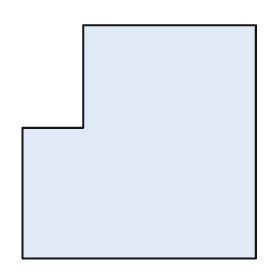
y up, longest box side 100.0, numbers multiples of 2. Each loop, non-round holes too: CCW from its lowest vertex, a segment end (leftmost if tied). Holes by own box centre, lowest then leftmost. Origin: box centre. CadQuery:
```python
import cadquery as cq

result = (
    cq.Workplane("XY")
    .moveTo(-50.0, -50.0)
    .lineTo(50.0, -50.0)
    .lineTo(50.0, 50.0)
    .lineTo(-24.0, 50.0)
    .lineTo(-24.0, 6.0)
    .lineTo(-50.0, 6.0)
    .close()
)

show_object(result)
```